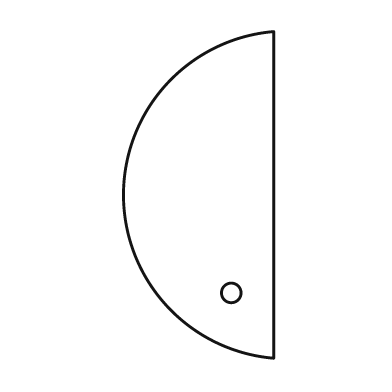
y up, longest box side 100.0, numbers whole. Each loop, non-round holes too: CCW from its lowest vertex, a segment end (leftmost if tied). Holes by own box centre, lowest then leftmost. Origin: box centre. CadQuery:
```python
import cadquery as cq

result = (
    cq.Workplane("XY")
    .moveTo(23.0, -50.0)
    .lineTo(23.0, 50.0)
    .threePointArc((-23.0, 0.0), (23.0, -50.0))
    .close()
    .moveTo(10.0, -30.0)
    .circle(3.0)
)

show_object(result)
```